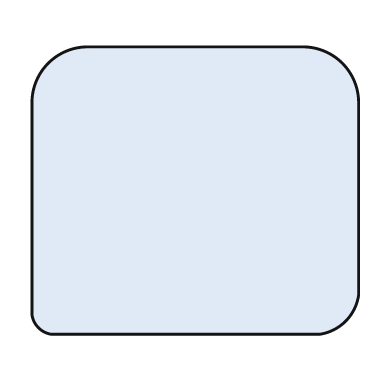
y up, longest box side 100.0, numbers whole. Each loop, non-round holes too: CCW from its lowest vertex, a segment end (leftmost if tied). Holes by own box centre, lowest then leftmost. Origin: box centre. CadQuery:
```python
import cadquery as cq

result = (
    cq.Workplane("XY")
    .moveTo(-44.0, -44.0)
    .lineTo(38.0, -44.0)
    .threePointArc((46.0, -40.0), (50.0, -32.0))
    .lineTo(50.0, 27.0)
    .threePointArc((45.0, 39.0), (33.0, 44.0))
    .lineTo(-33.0, 44.0)
    .threePointArc((-45.0, 39.0), (-50.0, 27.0))
    .lineTo(-50.0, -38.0)
    .threePointArc((-48.0, -42.0), (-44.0, -44.0))
    .close()
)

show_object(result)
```